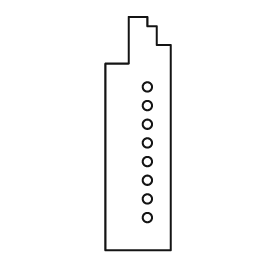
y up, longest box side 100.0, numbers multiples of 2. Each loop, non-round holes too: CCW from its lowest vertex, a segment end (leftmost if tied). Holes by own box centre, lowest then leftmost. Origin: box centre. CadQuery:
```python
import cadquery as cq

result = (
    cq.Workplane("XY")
    .moveTo(-14.0, -50.0)
    .lineTo(14.0, -50.0)
    .lineTo(14.0, 38.0)
    .lineTo(8.0, 38.0)
    .lineTo(8.0, 46.0)
    .lineTo(4.0, 46.0)
    .lineTo(4.0, 50.0)
    .lineTo(-4.0, 50.0)
    .lineTo(-4.0, 30.0)
    .lineTo(-14.0, 30.0)
    .close()
    .moveTo(4.0, -36.0)
    .circle(2.0)
    .moveTo(4.0, -28.0)
    .circle(2.0)
    .moveTo(4.0, -20.0)
    .circle(2.0)
    .moveTo(4.0, -12.0)
    .circle(2.0)
    .moveTo(4.0, -4.0)
    .circle(2.0)
    .moveTo(4.0, 4.0)
    .circle(2.0)
    .moveTo(4.0, 12.0)
    .circle(2.0)
    .moveTo(4.0, 20.0)
    .circle(2.0)
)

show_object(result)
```